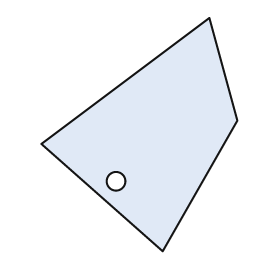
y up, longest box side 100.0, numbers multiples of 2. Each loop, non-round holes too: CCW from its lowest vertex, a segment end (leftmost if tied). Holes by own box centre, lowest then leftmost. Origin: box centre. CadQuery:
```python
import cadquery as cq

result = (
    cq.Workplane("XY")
    .moveTo(10.0, -50.0)
    .lineTo(42.0, 6.0)
    .lineTo(30.0, 50.0)
    .lineTo(-42.0, -4.0)
    .close()
    .moveTo(-10.0, -20.0)
    .circle(4.0)
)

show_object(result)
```